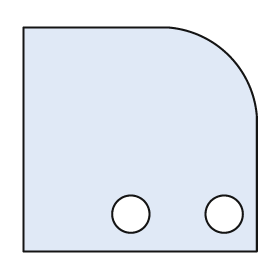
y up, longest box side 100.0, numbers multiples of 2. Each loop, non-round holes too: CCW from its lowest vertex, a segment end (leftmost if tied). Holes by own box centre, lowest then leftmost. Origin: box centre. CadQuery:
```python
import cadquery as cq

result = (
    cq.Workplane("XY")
    .moveTo(-50.0, -48.0)
    .lineTo(50.0, -48.0)
    .lineTo(50.0, 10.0)
    .threePointArc((38.0, 36.0), (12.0, 48.0))
    .lineTo(-50.0, 48.0)
    .close()
    .moveTo(-4.0, -32.0)
    .circle(8.0)
    .moveTo(36.0, -32.0)
    .circle(8.0)
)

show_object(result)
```